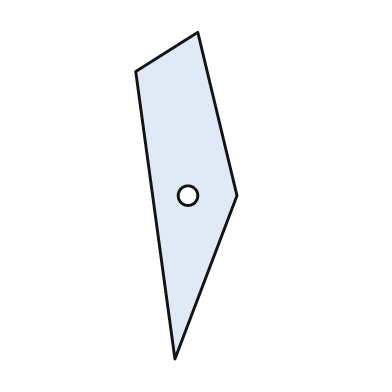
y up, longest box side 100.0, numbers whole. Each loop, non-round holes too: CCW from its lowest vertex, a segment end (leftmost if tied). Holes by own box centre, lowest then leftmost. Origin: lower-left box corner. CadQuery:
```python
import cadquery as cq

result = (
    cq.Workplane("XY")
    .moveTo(12.0, 0.0)
    .lineTo(31.0, 50.0)
    .lineTo(19.0, 100.0)
    .lineTo(0.0, 88.0)
    .close()
    .moveTo(16.0, 50.0)
    .circle(3.0)
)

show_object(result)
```